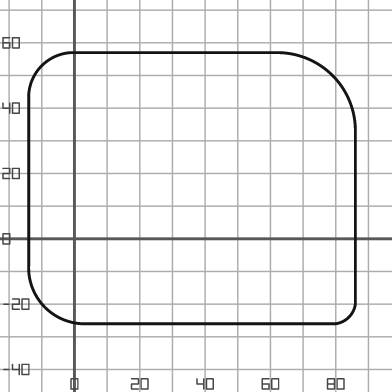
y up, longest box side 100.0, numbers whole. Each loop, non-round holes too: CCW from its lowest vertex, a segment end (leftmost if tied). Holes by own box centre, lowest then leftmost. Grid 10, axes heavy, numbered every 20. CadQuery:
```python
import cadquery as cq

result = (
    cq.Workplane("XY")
    .moveTo(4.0, -26.0)
    .lineTo(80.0, -26.0)
    .threePointArc((84.0, -24.0), (86.0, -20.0))
    .lineTo(86.0, 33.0)
    .threePointArc((79.0, 50.0), (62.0, 57.0))
    .lineTo(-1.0, 57.0)
    .threePointArc((-10.0, 53.0), (-14.0, 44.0))
    .lineTo(-14.0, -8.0)
    .threePointArc((-9.0, -21.0), (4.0, -26.0))
    .close()
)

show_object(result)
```